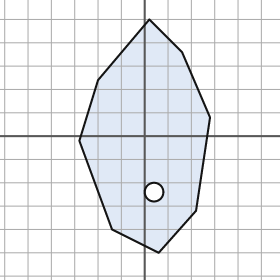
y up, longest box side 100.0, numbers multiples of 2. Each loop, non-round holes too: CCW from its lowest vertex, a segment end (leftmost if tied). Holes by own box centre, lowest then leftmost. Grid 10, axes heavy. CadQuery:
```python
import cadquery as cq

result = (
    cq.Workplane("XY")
    .moveTo(6.0, -50.0)
    .lineTo(22.0, -32.0)
    .lineTo(28.0, 8.0)
    .lineTo(16.0, 36.0)
    .lineTo(2.0, 50.0)
    .lineTo(-20.0, 24.0)
    .lineTo(-28.0, -2.0)
    .lineTo(-14.0, -40.0)
    .close()
    .moveTo(4.0, -24.0)
    .circle(4.0)
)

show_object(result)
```